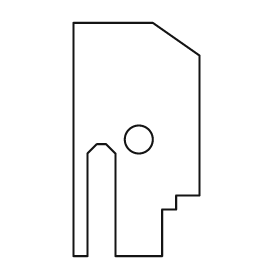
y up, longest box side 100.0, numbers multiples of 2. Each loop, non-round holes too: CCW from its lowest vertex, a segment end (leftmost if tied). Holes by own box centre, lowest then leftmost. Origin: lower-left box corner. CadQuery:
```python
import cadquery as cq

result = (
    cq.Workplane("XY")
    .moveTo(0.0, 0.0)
    .lineTo(6.0, 0.0)
    .lineTo(6.0, 44.0)
    .lineTo(10.0, 48.0)
    .lineTo(14.0, 48.0)
    .lineTo(18.0, 44.0)
    .lineTo(18.0, 0.0)
    .lineTo(38.0, 0.0)
    .lineTo(38.0, 20.0)
    .lineTo(44.0, 20.0)
    .lineTo(44.0, 26.0)
    .lineTo(54.0, 26.0)
    .lineTo(54.0, 86.0)
    .lineTo(34.0, 100.0)
    .lineTo(0.0, 100.0)
    .close()
    .moveTo(28.0, 50.0)
    .circle(6.0)
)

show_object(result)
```